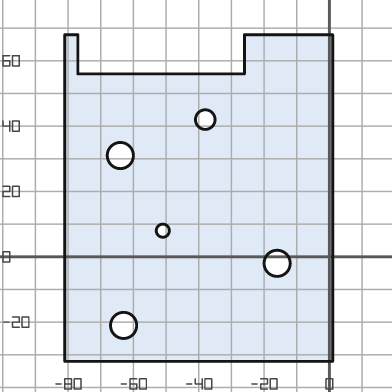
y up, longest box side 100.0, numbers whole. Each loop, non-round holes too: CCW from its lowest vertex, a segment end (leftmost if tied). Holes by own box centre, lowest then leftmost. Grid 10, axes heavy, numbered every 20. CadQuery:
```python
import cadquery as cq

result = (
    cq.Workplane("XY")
    .moveTo(-81.0, -32.0)
    .lineTo(1.0, -32.0)
    .lineTo(1.0, 68.0)
    .lineTo(-26.0, 68.0)
    .lineTo(-26.0, 56.0)
    .lineTo(-77.0, 56.0)
    .lineTo(-77.0, 68.0)
    .lineTo(-81.0, 68.0)
    .close()
    .moveTo(-63.0, -21.0)
    .circle(4.0)
    .moveTo(-16.0, -2.0)
    .circle(4.0)
    .moveTo(-51.0, 8.0)
    .circle(2.0)
    .moveTo(-64.0, 31.0)
    .circle(4.0)
    .moveTo(-38.0, 42.0)
    .circle(3.0)
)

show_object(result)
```